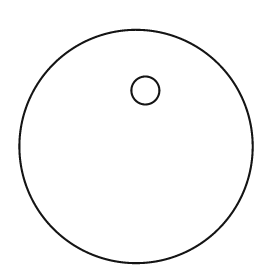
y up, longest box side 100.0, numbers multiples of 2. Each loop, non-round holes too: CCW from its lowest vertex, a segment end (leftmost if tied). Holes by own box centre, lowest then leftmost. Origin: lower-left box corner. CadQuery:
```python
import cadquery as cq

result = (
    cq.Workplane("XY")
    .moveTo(50.0, 50.0)
    .circle(50.0)
    .moveTo(54.0, 74.0)
    .circle(6.0)
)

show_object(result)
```